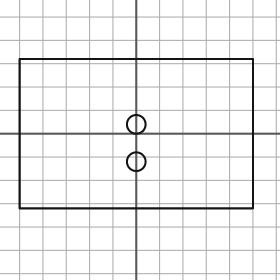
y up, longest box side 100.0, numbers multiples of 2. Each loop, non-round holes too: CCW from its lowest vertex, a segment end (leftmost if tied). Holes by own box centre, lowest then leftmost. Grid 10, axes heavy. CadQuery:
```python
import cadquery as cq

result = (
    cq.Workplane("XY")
    .moveTo(-50.0, -32.0)
    .lineTo(50.0, -32.0)
    .lineTo(50.0, 32.0)
    .lineTo(-50.0, 32.0)
    .close()
    .moveTo(0.0, -12.0)
    .circle(4.0)
    .moveTo(0.0, 4.0)
    .circle(4.0)
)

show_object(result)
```